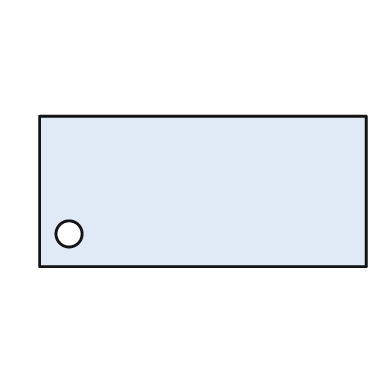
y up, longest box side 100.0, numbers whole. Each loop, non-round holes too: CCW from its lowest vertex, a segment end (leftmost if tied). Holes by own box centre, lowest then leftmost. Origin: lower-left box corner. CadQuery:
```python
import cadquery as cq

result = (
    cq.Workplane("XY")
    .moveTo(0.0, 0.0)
    .lineTo(100.0, 0.0)
    .lineTo(100.0, 46.0)
    .lineTo(0.0, 46.0)
    .close()
    .moveTo(9.0, 10.0)
    .circle(4.0)
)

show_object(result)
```